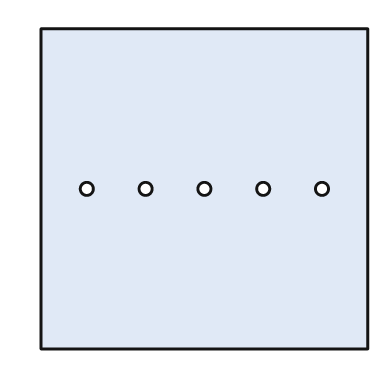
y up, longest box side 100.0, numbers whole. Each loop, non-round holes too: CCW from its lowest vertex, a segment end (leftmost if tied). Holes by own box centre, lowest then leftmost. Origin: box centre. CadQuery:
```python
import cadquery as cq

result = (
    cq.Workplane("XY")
    .moveTo(-50.0, -49.0)
    .lineTo(50.0, -49.0)
    .lineTo(50.0, 49.0)
    .lineTo(-50.0, 49.0)
    .close()
    .moveTo(-36.0, 0.0)
    .circle(2.0)
    .moveTo(-18.0, 0.0)
    .circle(2.0)
    .moveTo(0.0, 0.0)
    .circle(2.0)
    .moveTo(18.0, 0.0)
    .circle(2.0)
    .moveTo(36.0, 0.0)
    .circle(2.0)
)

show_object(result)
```